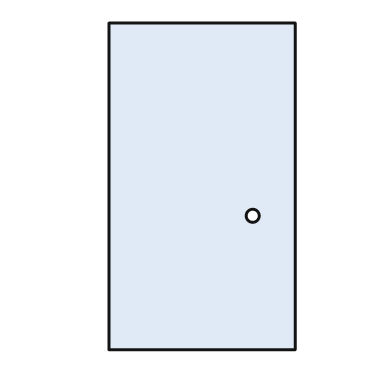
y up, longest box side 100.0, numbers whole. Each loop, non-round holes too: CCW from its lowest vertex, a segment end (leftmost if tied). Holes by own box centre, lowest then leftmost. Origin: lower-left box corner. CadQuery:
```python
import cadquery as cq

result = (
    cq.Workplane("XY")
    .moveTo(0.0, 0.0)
    .lineTo(57.0, 0.0)
    .lineTo(57.0, 100.0)
    .lineTo(0.0, 100.0)
    .close()
    .moveTo(44.0, 41.0)
    .circle(2.0)
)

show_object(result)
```